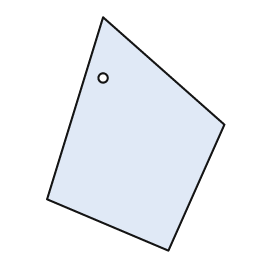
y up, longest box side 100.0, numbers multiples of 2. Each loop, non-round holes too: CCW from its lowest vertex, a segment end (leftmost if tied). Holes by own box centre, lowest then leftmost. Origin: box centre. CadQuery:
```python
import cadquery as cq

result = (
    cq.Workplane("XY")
    .moveTo(14.0, -50.0)
    .lineTo(38.0, 4.0)
    .lineTo(-14.0, 50.0)
    .lineTo(-38.0, -28.0)
    .close()
    .moveTo(-14.0, 24.0)
    .circle(2.0)
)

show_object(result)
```